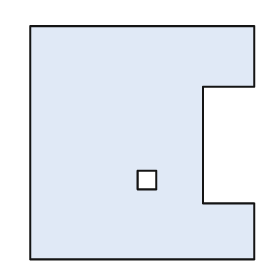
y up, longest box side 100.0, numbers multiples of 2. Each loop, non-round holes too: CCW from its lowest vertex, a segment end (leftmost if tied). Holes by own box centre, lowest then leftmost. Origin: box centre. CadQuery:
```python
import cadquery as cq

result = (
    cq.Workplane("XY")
    .moveTo(-48.0, -50.0)
    .lineTo(48.0, -50.0)
    .lineTo(48.0, -26.0)
    .lineTo(26.0, -26.0)
    .lineTo(26.0, 24.0)
    .lineTo(48.0, 24.0)
    .lineTo(48.0, 50.0)
    .lineTo(-48.0, 50.0)
    .close()
    .moveTo(-2.0, -20.0)
    .lineTo(6.0, -20.0)
    .lineTo(6.0, -12.0)
    .lineTo(-2.0, -12.0)
    .close()
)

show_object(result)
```